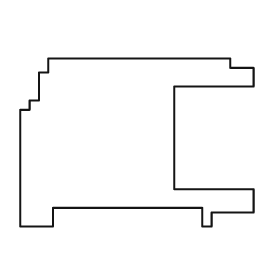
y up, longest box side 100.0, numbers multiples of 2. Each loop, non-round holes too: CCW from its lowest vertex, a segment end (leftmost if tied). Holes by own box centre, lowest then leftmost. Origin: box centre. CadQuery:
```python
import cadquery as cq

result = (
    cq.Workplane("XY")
    .moveTo(-50.0, -36.0)
    .lineTo(-36.0, -36.0)
    .lineTo(-36.0, -28.0)
    .lineTo(28.0, -28.0)
    .lineTo(28.0, -36.0)
    .lineTo(32.0, -36.0)
    .lineTo(32.0, -30.0)
    .lineTo(50.0, -30.0)
    .lineTo(50.0, -20.0)
    .lineTo(16.0, -20.0)
    .lineTo(16.0, 24.0)
    .lineTo(50.0, 24.0)
    .lineTo(50.0, 32.0)
    .lineTo(40.0, 32.0)
    .lineTo(40.0, 36.0)
    .lineTo(-38.0, 36.0)
    .lineTo(-38.0, 30.0)
    .lineTo(-42.0, 30.0)
    .lineTo(-42.0, 18.0)
    .lineTo(-46.0, 18.0)
    .lineTo(-46.0, 14.0)
    .lineTo(-50.0, 14.0)
    .close()
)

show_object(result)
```